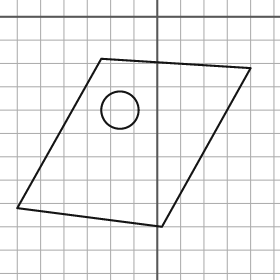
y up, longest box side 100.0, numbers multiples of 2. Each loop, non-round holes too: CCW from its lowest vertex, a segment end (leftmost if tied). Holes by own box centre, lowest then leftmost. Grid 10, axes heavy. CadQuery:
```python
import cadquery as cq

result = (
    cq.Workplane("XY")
    .moveTo(2.0, -90.0)
    .lineTo(40.0, -22.0)
    .lineTo(-24.0, -18.0)
    .lineTo(-60.0, -82.0)
    .close()
    .moveTo(-16.0, -40.0)
    .circle(8.0)
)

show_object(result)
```